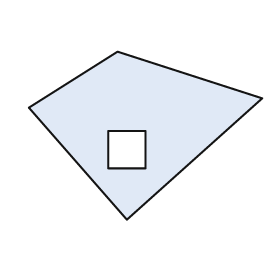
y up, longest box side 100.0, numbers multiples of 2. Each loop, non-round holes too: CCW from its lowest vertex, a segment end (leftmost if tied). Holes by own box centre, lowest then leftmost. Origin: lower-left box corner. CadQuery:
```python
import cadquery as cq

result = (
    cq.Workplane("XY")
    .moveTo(42.0, 0.0)
    .lineTo(100.0, 52.0)
    .lineTo(38.0, 72.0)
    .lineTo(0.0, 48.0)
    .close()
    .moveTo(34.0, 22.0)
    .lineTo(50.0, 22.0)
    .lineTo(50.0, 38.0)
    .lineTo(34.0, 38.0)
    .close()
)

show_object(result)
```